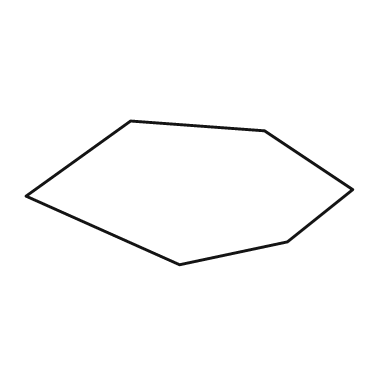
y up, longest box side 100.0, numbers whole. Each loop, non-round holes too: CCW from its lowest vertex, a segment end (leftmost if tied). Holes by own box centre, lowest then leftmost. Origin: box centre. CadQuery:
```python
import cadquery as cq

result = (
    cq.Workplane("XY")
    .moveTo(-3.0, -22.0)
    .lineTo(30.0, -15.0)
    .lineTo(50.0, 1.0)
    .lineTo(23.0, 19.0)
    .lineTo(-18.0, 22.0)
    .lineTo(-50.0, -1.0)
    .close()
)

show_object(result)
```